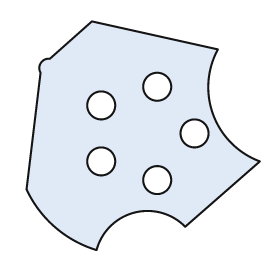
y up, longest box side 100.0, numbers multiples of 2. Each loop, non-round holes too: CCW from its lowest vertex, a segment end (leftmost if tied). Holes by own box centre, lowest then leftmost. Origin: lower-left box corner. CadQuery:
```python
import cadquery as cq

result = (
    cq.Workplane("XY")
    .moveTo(30.0, 0.0)
    .threePointArc((46.0, 16.0), (68.0, 10.0))
    .lineTo(100.0, 38.0)
    .threePointArc((80.0, 58.0), (82.0, 86.0))
    .lineTo(28.0, 98.0)
    .lineTo(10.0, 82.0)
    .threePointArc((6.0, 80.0), (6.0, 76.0))
    .lineTo(0.0, 26.0)
    .threePointArc((12.0, 10.0), (30.0, 0.0))
    .close()
    .moveTo(56.0, 30.0)
    .circle(6.0)
    .moveTo(32.0, 38.0)
    .circle(6.0)
    .moveTo(72.0, 50.0)
    .circle(6.0)
    .moveTo(32.0, 62.0)
    .circle(6.0)
    .moveTo(56.0, 70.0)
    .circle(6.0)
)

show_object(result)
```